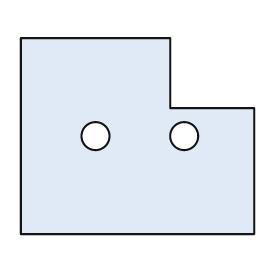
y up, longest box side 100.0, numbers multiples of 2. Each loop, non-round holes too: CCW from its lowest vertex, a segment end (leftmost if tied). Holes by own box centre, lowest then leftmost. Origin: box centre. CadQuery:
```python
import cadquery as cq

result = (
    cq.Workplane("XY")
    .moveTo(-50.0, -42.0)
    .lineTo(50.0, -42.0)
    .lineTo(50.0, 12.0)
    .lineTo(14.0, 12.0)
    .lineTo(14.0, 42.0)
    .lineTo(-50.0, 42.0)
    .close()
    .moveTo(-18.0, 0.0)
    .circle(6.0)
    .moveTo(20.0, 0.0)
    .circle(6.0)
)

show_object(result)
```